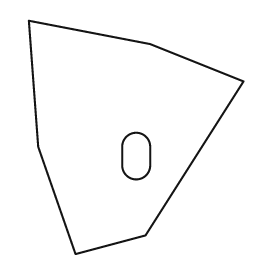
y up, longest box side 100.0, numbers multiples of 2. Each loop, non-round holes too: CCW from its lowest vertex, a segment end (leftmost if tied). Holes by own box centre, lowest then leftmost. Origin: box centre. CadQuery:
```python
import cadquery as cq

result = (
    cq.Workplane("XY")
    .moveTo(-26.0, -50.0)
    .lineTo(4.0, -42.0)
    .lineTo(46.0, 24.0)
    .lineTo(6.0, 40.0)
    .lineTo(-46.0, 50.0)
    .lineTo(-42.0, -4.0)
    .close()
    .moveTo(-6.0, -12.0)
    .threePointArc((0.0, -18.0), (6.0, -12.0))
    .lineTo(6.0, -4.0)
    .threePointArc((0.0, 2.0), (-6.0, -4.0))
    .close()
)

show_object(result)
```